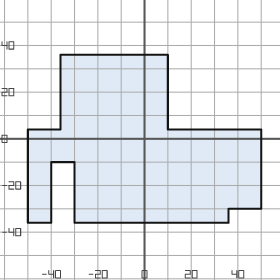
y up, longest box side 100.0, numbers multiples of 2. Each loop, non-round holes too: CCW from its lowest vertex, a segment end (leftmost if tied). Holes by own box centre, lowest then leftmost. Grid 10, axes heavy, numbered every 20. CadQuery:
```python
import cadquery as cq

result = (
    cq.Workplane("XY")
    .moveTo(-50.0, -36.0)
    .lineTo(-40.0, -36.0)
    .lineTo(-40.0, -10.0)
    .lineTo(-30.0, -10.0)
    .lineTo(-30.0, -36.0)
    .lineTo(36.0, -36.0)
    .lineTo(36.0, -30.0)
    .lineTo(50.0, -30.0)
    .lineTo(50.0, 4.0)
    .lineTo(10.0, 4.0)
    .lineTo(10.0, 36.0)
    .lineTo(-36.0, 36.0)
    .lineTo(-36.0, 4.0)
    .lineTo(-50.0, 4.0)
    .close()
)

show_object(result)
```